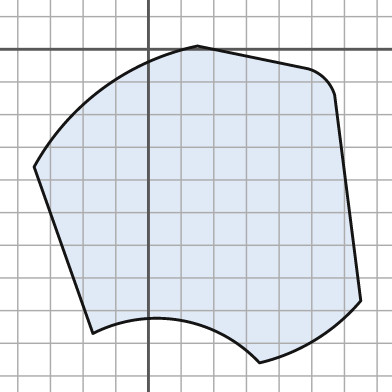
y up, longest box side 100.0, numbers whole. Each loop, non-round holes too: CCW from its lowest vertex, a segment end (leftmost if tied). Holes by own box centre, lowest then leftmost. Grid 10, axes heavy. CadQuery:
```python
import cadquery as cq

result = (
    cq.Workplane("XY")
    .moveTo(34.0, -96.0)
    .threePointArc((51.0, -89.0), (65.0, -77.0))
    .lineTo(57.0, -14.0)
    .threePointArc((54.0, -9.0), (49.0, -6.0))
    .lineTo(15.0, 1.0)
    .threePointArc((-14.0, -12.0), (-35.0, -36.0))
    .lineTo(-17.0, -87.0)
    .threePointArc((10.0, -83.0), (34.0, -96.0))
    .close()
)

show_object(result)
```